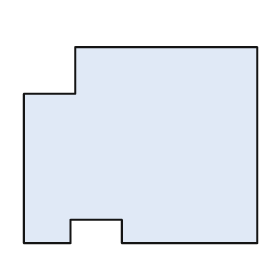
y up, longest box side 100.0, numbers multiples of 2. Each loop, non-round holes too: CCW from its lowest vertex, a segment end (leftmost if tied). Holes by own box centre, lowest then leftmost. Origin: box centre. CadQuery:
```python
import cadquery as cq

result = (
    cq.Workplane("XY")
    .moveTo(-50.0, -42.0)
    .lineTo(-30.0, -42.0)
    .lineTo(-30.0, -32.0)
    .lineTo(-8.0, -32.0)
    .lineTo(-8.0, -42.0)
    .lineTo(50.0, -42.0)
    .lineTo(50.0, 42.0)
    .lineTo(-28.0, 42.0)
    .lineTo(-28.0, 22.0)
    .lineTo(-50.0, 22.0)
    .close()
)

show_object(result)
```